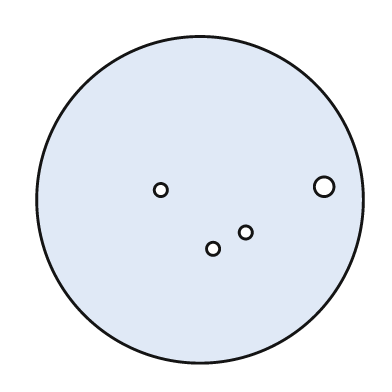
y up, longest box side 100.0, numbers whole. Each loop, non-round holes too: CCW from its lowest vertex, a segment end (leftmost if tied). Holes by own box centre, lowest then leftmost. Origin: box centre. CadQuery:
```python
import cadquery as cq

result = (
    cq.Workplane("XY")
    .moveTo(0.0, 0.0)
    .circle(50.0)
    .moveTo(4.0, -15.0)
    .circle(2.0)
    .moveTo(14.0, -10.0)
    .circle(2.0)
    .moveTo(-12.0, 3.0)
    .circle(2.0)
    .moveTo(38.0, 4.0)
    .circle(3.0)
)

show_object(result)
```